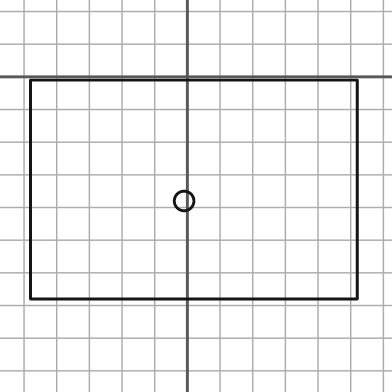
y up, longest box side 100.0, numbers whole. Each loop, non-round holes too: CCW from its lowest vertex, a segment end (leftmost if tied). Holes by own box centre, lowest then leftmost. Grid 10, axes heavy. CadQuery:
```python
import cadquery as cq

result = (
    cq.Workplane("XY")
    .moveTo(-48.0, -68.0)
    .lineTo(52.0, -68.0)
    .lineTo(52.0, -1.0)
    .lineTo(-48.0, -1.0)
    .close()
    .moveTo(-1.0, -38.0)
    .circle(3.0)
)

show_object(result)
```